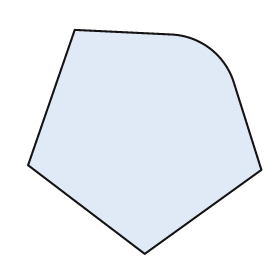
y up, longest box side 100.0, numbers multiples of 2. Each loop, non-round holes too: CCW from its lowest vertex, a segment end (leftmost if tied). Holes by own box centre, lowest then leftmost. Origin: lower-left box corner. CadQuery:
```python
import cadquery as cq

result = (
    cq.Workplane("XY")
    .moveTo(50.0, 0.0)
    .lineTo(100.0, 36.0)
    .lineTo(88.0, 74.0)
    .threePointArc((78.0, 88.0), (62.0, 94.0))
    .lineTo(20.0, 96.0)
    .lineTo(0.0, 38.0)
    .close()
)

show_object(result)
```